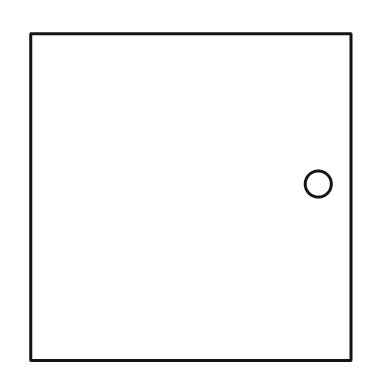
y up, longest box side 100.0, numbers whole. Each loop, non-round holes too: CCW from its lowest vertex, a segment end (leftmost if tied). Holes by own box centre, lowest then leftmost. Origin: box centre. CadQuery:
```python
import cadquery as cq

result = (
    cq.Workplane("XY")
    .moveTo(-49.0, -50.0)
    .lineTo(49.0, -50.0)
    .lineTo(49.0, 50.0)
    .lineTo(-49.0, 50.0)
    .close()
    .moveTo(39.0, 4.0)
    .circle(4.0)
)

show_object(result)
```